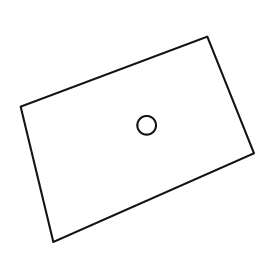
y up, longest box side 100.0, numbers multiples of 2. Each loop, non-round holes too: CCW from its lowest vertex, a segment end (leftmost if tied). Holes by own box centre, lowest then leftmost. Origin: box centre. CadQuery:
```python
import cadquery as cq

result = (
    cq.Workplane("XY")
    .moveTo(-36.0, -44.0)
    .lineTo(50.0, -6.0)
    .lineTo(30.0, 44.0)
    .lineTo(-50.0, 14.0)
    .close()
    .moveTo(4.0, 6.0)
    .circle(4.0)
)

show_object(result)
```